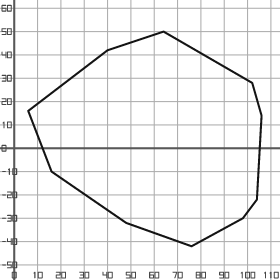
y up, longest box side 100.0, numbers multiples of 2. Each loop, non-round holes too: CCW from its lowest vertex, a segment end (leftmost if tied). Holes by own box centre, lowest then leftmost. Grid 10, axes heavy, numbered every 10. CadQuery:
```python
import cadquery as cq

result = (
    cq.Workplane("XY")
    .moveTo(76.0, -42.0)
    .lineTo(98.0, -30.0)
    .lineTo(104.0, -22.0)
    .lineTo(106.0, 14.0)
    .lineTo(102.0, 28.0)
    .lineTo(64.0, 50.0)
    .lineTo(40.0, 42.0)
    .lineTo(6.0, 16.0)
    .lineTo(16.0, -10.0)
    .lineTo(48.0, -32.0)
    .close()
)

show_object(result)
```